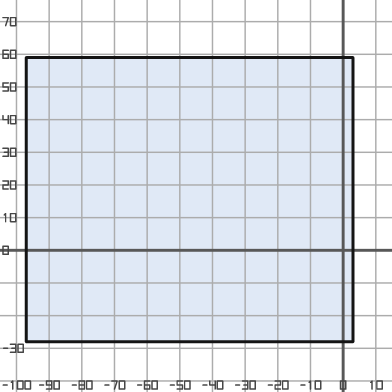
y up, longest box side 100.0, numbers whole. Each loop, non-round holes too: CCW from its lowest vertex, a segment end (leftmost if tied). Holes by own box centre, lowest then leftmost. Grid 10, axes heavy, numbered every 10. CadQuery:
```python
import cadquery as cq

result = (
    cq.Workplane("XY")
    .moveTo(-97.0, -28.0)
    .lineTo(3.0, -28.0)
    .lineTo(3.0, 59.0)
    .lineTo(-97.0, 59.0)
    .close()
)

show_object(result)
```